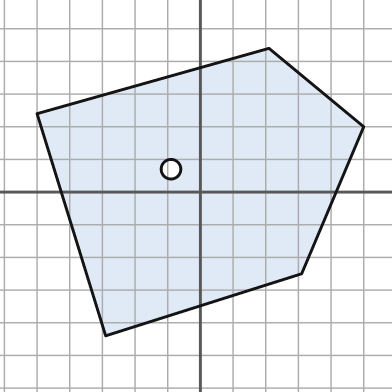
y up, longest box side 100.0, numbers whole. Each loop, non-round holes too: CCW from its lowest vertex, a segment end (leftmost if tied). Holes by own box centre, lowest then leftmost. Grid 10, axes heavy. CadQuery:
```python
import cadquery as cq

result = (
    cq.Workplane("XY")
    .moveTo(-29.0, -44.0)
    .lineTo(31.0, -25.0)
    .lineTo(50.0, 20.0)
    .lineTo(21.0, 44.0)
    .lineTo(-50.0, 24.0)
    .close()
    .moveTo(-9.0, 7.0)
    .circle(3.0)
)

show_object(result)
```